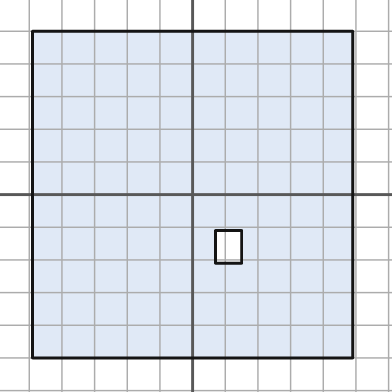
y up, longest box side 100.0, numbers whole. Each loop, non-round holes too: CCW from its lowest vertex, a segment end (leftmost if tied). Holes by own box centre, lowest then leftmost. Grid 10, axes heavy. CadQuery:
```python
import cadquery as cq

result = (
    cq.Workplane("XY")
    .moveTo(-49.0, -50.0)
    .lineTo(49.0, -50.0)
    .lineTo(49.0, 50.0)
    .lineTo(-49.0, 50.0)
    .close()
    .moveTo(7.0, -21.0)
    .lineTo(15.0, -21.0)
    .lineTo(15.0, -11.0)
    .lineTo(7.0, -11.0)
    .close()
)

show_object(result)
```